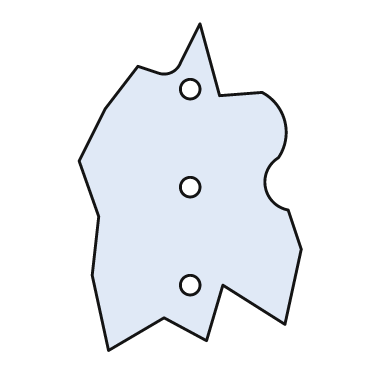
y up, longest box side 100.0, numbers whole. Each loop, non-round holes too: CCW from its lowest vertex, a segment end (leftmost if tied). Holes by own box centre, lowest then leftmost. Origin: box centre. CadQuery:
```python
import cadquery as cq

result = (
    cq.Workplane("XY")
    .moveTo(-25.0, -50.0)
    .lineTo(-8.0, -40.0)
    .lineTo(5.0, -47.0)
    .lineTo(10.0, -30.0)
    .lineTo(29.0, -42.0)
    .lineTo(34.0, -19.0)
    .lineTo(30.0, -7.0)
    .threePointArc((23.0, 0.0), (27.0, 9.0))
    .threePointArc((29.0, 20.0), (22.0, 29.0))
    .lineTo(9.0, 28.0)
    .lineTo(3.0, 50.0)
    .lineTo(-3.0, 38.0)
    .threePointArc((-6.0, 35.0), (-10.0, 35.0))
    .lineTo(-16.0, 37.0)
    .lineTo(-26.0, 24.0)
    .lineTo(-34.0, 8.0)
    .lineTo(-28.0, -9.0)
    .lineTo(-30.0, -27.0)
    .close()
    .moveTo(0.0, -30.0)
    .circle(3.0)
    .moveTo(0.0, 0.0)
    .circle(3.0)
    .moveTo(0.0, 30.0)
    .circle(3.0)
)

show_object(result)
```